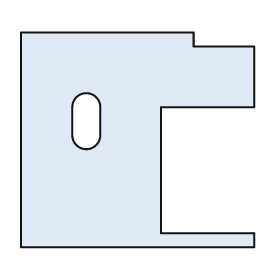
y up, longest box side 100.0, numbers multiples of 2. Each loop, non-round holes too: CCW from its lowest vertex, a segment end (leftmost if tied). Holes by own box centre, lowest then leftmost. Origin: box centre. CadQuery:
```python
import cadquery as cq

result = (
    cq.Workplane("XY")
    .moveTo(-50.0, -46.0)
    .lineTo(50.0, -46.0)
    .lineTo(50.0, -40.0)
    .lineTo(10.0, -40.0)
    .lineTo(10.0, 14.0)
    .lineTo(50.0, 14.0)
    .lineTo(50.0, 40.0)
    .lineTo(24.0, 40.0)
    .lineTo(24.0, 46.0)
    .lineTo(-50.0, 46.0)
    .close()
    .moveTo(-28.0, 2.0)
    .threePointArc((-22.0, -4.0), (-16.0, 2.0))
    .lineTo(-16.0, 14.0)
    .threePointArc((-22.0, 20.0), (-28.0, 14.0))
    .close()
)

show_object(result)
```